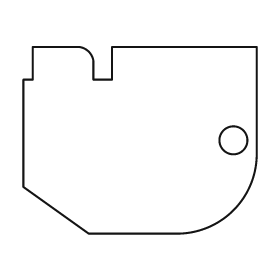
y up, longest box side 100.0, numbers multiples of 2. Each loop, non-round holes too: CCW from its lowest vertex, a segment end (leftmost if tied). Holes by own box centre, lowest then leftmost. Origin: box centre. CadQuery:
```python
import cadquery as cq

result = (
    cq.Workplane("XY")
    .moveTo(-22.0, -40.0)
    .lineTo(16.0, -40.0)
    .threePointArc((40.0, -30.0), (50.0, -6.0))
    .lineTo(50.0, 40.0)
    .lineTo(-12.0, 40.0)
    .lineTo(-12.0, 26.0)
    .lineTo(-20.0, 26.0)
    .lineTo(-20.0, 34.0)
    .threePointArc((-22.0, 38.0), (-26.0, 40.0))
    .lineTo(-46.0, 40.0)
    .lineTo(-46.0, 26.0)
    .lineTo(-50.0, 26.0)
    .lineTo(-50.0, -20.0)
    .close()
    .moveTo(40.0, 0.0)
    .circle(6.0)
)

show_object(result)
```